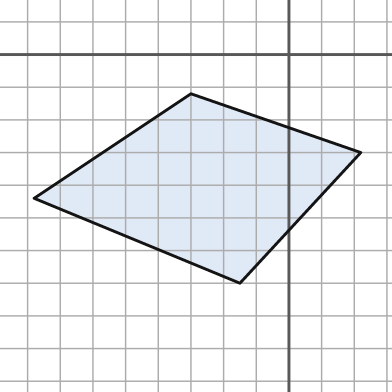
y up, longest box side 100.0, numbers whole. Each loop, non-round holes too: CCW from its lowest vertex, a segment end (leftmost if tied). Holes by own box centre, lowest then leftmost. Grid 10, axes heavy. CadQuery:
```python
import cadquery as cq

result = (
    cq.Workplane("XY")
    .moveTo(-15.0, -70.0)
    .lineTo(22.0, -30.0)
    .lineTo(-30.0, -12.0)
    .lineTo(-78.0, -44.0)
    .close()
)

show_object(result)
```